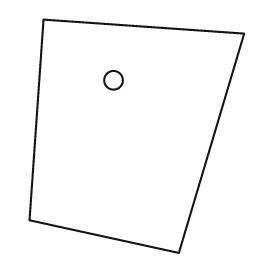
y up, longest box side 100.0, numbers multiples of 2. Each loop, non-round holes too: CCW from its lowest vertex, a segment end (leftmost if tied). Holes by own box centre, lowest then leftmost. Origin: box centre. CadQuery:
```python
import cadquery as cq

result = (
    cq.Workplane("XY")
    .moveTo(18.0, -50.0)
    .lineTo(46.0, 44.0)
    .lineTo(-40.0, 50.0)
    .lineTo(-46.0, -36.0)
    .close()
    .moveTo(-10.0, 24.0)
    .circle(4.0)
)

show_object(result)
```